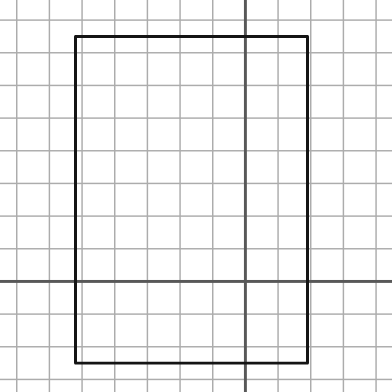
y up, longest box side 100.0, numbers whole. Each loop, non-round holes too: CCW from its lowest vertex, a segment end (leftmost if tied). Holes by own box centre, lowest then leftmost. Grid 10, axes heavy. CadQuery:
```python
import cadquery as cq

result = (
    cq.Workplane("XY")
    .moveTo(-52.0, -25.0)
    .lineTo(19.0, -25.0)
    .lineTo(19.0, 75.0)
    .lineTo(-52.0, 75.0)
    .close()
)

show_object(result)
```